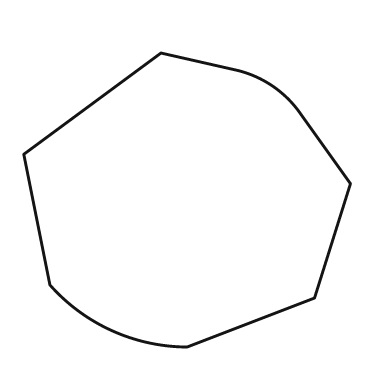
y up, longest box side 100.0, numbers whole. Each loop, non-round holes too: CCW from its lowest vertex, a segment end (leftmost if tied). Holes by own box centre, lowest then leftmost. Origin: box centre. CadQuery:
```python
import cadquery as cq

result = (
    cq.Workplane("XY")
    .moveTo(0.0, -45.0)
    .lineTo(39.0, -30.0)
    .lineTo(50.0, 5.0)
    .lineTo(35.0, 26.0)
    .threePointArc((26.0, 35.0), (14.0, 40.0))
    .lineTo(-8.0, 45.0)
    .lineTo(-50.0, 14.0)
    .lineTo(-42.0, -26.0)
    .threePointArc((-23.0, -40.0), (0.0, -45.0))
    .close()
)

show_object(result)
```